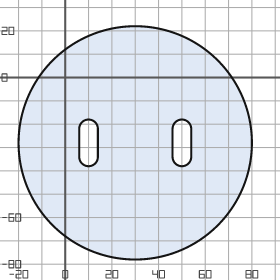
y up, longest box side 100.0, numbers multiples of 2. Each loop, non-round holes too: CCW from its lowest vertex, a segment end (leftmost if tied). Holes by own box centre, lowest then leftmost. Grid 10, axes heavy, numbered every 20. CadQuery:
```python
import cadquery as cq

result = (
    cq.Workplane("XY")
    .moveTo(30.0, -28.0)
    .circle(50.0)
    .moveTo(6.0, -34.0)
    .threePointArc((10.0, -38.0), (14.0, -34.0))
    .lineTo(14.0, -22.0)
    .threePointArc((10.0, -18.0), (6.0, -22.0))
    .close()
    .moveTo(46.0, -34.0)
    .threePointArc((50.0, -38.0), (54.0, -34.0))
    .lineTo(54.0, -22.0)
    .threePointArc((50.0, -18.0), (46.0, -22.0))
    .close()
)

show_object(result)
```